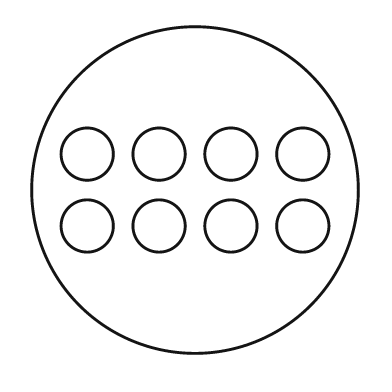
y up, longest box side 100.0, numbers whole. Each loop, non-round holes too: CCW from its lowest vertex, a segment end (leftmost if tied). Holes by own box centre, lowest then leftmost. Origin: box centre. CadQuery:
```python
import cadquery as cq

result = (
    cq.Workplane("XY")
    .moveTo(0.0, 0.0)
    .circle(50.0)
    .moveTo(-33.0, -11.0)
    .circle(8.0)
    .moveTo(-11.0, -11.0)
    .circle(8.0)
    .moveTo(11.0, -11.0)
    .circle(8.0)
    .moveTo(33.0, -11.0)
    .circle(8.0)
    .moveTo(-33.0, 11.0)
    .circle(8.0)
    .moveTo(-11.0, 11.0)
    .circle(8.0)
    .moveTo(11.0, 11.0)
    .circle(8.0)
    .moveTo(33.0, 11.0)
    .circle(8.0)
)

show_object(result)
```